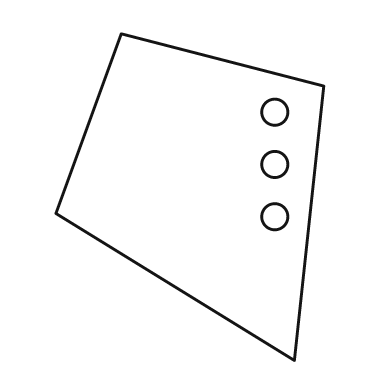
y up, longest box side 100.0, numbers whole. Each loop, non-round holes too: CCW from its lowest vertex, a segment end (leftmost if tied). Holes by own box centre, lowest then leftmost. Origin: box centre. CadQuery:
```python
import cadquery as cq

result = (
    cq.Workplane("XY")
    .moveTo(32.0, -50.0)
    .lineTo(41.0, 34.0)
    .lineTo(-21.0, 50.0)
    .lineTo(-41.0, -5.0)
    .close()
    .moveTo(26.0, -6.0)
    .circle(4.0)
    .moveTo(26.0, 10.0)
    .circle(4.0)
    .moveTo(26.0, 26.0)
    .circle(4.0)
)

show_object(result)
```